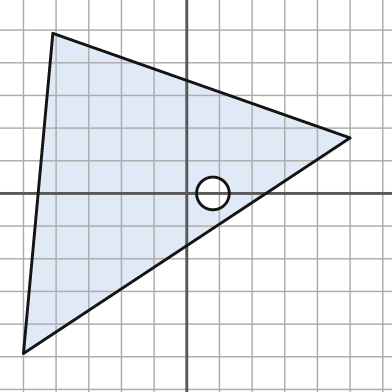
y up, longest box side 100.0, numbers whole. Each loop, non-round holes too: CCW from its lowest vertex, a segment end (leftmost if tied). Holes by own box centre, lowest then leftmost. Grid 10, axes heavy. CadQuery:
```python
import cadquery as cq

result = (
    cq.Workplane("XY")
    .moveTo(-50.0, -49.0)
    .lineTo(50.0, 17.0)
    .lineTo(-41.0, 49.0)
    .close()
    .moveTo(8.0, 0.0)
    .circle(5.0)
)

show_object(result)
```